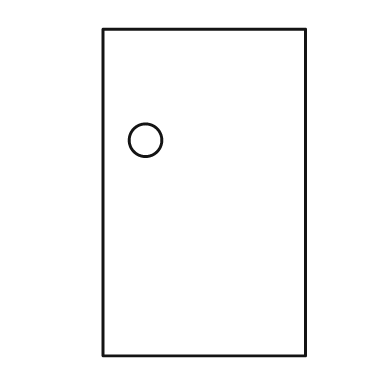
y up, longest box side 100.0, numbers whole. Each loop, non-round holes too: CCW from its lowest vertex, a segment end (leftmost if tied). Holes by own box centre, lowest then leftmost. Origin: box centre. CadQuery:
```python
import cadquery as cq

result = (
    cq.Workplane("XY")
    .moveTo(-31.0, -50.0)
    .lineTo(31.0, -50.0)
    .lineTo(31.0, 50.0)
    .lineTo(-31.0, 50.0)
    .close()
    .moveTo(-18.0, 16.0)
    .circle(5.0)
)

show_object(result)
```